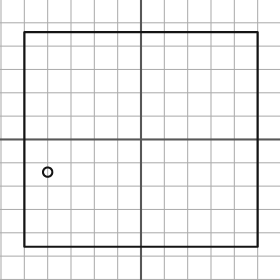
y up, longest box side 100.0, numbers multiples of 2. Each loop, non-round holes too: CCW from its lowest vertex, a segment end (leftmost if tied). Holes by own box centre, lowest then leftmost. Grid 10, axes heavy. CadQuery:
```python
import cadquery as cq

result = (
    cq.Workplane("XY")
    .moveTo(-50.0, -46.0)
    .lineTo(50.0, -46.0)
    .lineTo(50.0, 46.0)
    .lineTo(-50.0, 46.0)
    .close()
    .moveTo(-40.0, -14.0)
    .circle(2.0)
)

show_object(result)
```